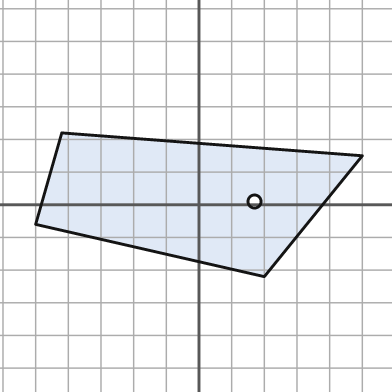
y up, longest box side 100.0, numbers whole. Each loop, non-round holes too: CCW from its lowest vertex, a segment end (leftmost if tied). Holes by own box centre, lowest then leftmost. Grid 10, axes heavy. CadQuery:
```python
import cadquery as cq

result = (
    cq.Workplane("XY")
    .moveTo(20.0, -22.0)
    .lineTo(50.0, 15.0)
    .lineTo(-42.0, 22.0)
    .lineTo(-50.0, -6.0)
    .close()
    .moveTo(17.0, 1.0)
    .circle(2.0)
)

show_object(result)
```